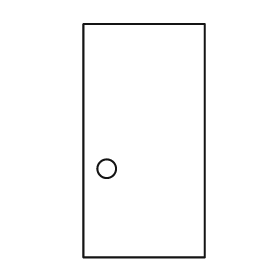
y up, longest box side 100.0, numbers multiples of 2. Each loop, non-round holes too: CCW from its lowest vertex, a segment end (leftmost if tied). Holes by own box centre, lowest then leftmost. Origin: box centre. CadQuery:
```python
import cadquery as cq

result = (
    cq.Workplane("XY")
    .moveTo(-26.0, -50.0)
    .lineTo(26.0, -50.0)
    .lineTo(26.0, 50.0)
    .lineTo(-26.0, 50.0)
    .close()
    .moveTo(-16.0, -12.0)
    .circle(4.0)
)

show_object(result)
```